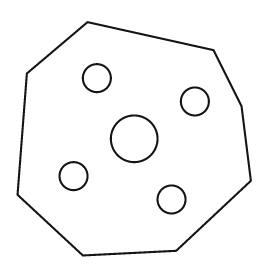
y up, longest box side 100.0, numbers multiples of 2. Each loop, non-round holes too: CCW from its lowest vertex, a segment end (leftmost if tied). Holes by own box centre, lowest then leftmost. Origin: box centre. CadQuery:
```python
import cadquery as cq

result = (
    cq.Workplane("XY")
    .moveTo(-22.0, -50.0)
    .lineTo(18.0, -48.0)
    .lineTo(50.0, -18.0)
    .lineTo(46.0, 14.0)
    .lineTo(34.0, 38.0)
    .lineTo(-20.0, 50.0)
    .lineTo(-46.0, 28.0)
    .lineTo(-50.0, -24.0)
    .close()
    .moveTo(16.0, -26.0)
    .circle(6.0)
    .moveTo(-26.0, -16.0)
    .circle(6.0)
    .moveTo(0.0, 0.0)
    .circle(10.0)
    .moveTo(26.0, 16.0)
    .circle(6.0)
    .moveTo(-16.0, 26.0)
    .circle(6.0)
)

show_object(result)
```